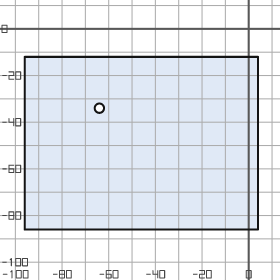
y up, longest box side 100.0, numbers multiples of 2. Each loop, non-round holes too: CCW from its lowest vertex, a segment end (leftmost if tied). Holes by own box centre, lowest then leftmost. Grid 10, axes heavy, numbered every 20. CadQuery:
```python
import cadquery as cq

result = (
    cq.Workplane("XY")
    .moveTo(-96.0, -86.0)
    .lineTo(4.0, -86.0)
    .lineTo(4.0, -12.0)
    .lineTo(-96.0, -12.0)
    .close()
    .moveTo(-64.0, -34.0)
    .circle(2.0)
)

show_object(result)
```